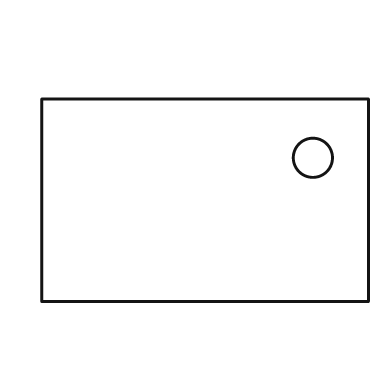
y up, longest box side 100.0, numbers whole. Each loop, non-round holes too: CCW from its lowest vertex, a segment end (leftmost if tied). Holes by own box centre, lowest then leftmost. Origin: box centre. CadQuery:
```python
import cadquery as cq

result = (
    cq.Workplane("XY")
    .moveTo(-50.0, -31.0)
    .lineTo(50.0, -31.0)
    .lineTo(50.0, 31.0)
    .lineTo(-50.0, 31.0)
    .close()
    .moveTo(33.0, 13.0)
    .circle(6.0)
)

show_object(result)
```